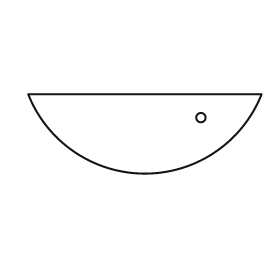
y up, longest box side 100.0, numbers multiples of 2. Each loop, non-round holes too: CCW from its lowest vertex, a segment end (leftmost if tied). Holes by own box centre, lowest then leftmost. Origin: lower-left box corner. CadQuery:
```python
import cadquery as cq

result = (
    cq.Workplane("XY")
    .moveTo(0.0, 34.0)
    .threePointArc((50.0, 0.0), (100.0, 34.0))
    .close()
    .moveTo(74.0, 24.0)
    .circle(2.0)
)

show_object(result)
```